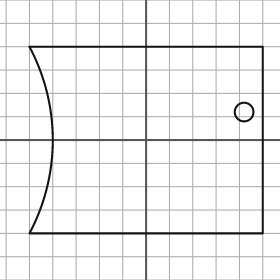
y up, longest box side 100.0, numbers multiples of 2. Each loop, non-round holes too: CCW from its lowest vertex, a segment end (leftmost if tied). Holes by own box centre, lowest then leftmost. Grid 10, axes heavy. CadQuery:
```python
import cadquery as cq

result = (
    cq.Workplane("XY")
    .moveTo(-50.0, -40.0)
    .lineTo(50.0, -40.0)
    .lineTo(50.0, 40.0)
    .lineTo(-50.0, 40.0)
    .threePointArc((-40.0, 0.0), (-50.0, -40.0))
    .close()
    .moveTo(42.0, 12.0)
    .circle(4.0)
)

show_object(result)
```